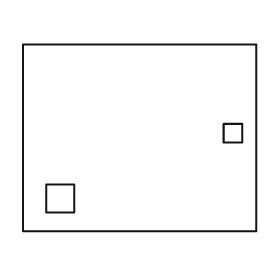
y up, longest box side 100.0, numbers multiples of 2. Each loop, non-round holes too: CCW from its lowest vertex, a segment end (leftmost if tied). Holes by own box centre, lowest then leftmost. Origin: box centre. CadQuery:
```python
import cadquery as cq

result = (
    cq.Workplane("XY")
    .moveTo(-50.0, -40.0)
    .lineTo(50.0, -40.0)
    .lineTo(50.0, 40.0)
    .lineTo(-50.0, 40.0)
    .close()
    .moveTo(-40.0, -32.0)
    .lineTo(-28.0, -32.0)
    .lineTo(-28.0, -20.0)
    .lineTo(-40.0, -20.0)
    .close()
    .moveTo(36.0, -2.0)
    .lineTo(44.0, -2.0)
    .lineTo(44.0, 6.0)
    .lineTo(36.0, 6.0)
    .close()
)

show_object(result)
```